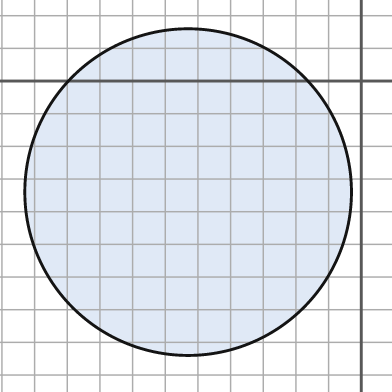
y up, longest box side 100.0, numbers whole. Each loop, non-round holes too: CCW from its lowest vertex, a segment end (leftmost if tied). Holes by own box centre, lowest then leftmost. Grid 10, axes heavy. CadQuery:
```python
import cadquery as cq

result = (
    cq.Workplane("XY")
    .moveTo(-53.0, -34.0)
    .circle(50.0)
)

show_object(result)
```